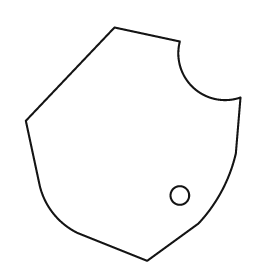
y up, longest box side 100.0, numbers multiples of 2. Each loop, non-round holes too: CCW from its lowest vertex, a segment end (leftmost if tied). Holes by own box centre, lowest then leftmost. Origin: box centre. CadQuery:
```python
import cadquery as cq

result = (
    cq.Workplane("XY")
    .moveTo(6.0, -50.0)
    .lineTo(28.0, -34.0)
    .threePointArc((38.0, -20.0), (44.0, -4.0))
    .lineTo(46.0, 20.0)
    .threePointArc((26.0, 24.0), (20.0, 44.0))
    .lineTo(-8.0, 50.0)
    .lineTo(-46.0, 10.0)
    .lineTo(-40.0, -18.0)
    .threePointArc((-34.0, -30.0), (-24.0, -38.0))
    .close()
    .moveTo(20.0, -22.0)
    .circle(4.0)
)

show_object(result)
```